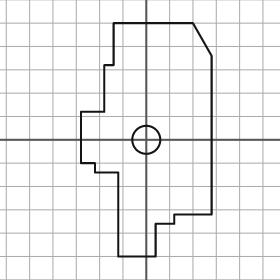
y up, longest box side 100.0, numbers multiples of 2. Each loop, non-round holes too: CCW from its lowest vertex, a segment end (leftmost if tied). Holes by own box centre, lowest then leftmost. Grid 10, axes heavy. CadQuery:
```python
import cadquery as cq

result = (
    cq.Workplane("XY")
    .moveTo(-12.0, -50.0)
    .lineTo(4.0, -50.0)
    .lineTo(4.0, -36.0)
    .lineTo(12.0, -36.0)
    .lineTo(12.0, -32.0)
    .lineTo(28.0, -32.0)
    .lineTo(28.0, 36.0)
    .lineTo(20.0, 50.0)
    .lineTo(-14.0, 50.0)
    .lineTo(-14.0, 32.0)
    .lineTo(-18.0, 32.0)
    .lineTo(-18.0, 12.0)
    .lineTo(-28.0, 12.0)
    .lineTo(-28.0, -10.0)
    .lineTo(-22.0, -10.0)
    .lineTo(-22.0, -14.0)
    .lineTo(-12.0, -14.0)
    .close()
    .moveTo(0.0, 0.0)
    .circle(6.0)
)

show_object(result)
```